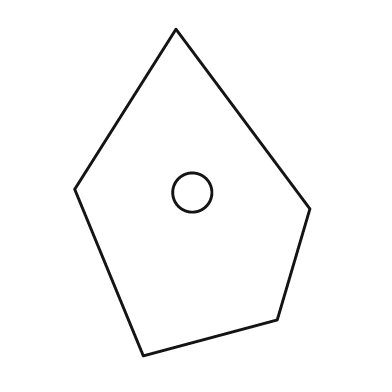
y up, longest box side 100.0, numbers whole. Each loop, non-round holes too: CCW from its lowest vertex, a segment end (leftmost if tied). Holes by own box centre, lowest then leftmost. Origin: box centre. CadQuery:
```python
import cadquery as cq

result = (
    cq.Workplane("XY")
    .moveTo(-15.0, -50.0)
    .lineTo(26.0, -39.0)
    .lineTo(36.0, -5.0)
    .lineTo(-5.0, 50.0)
    .lineTo(-36.0, 1.0)
    .close()
    .moveTo(0.0, 0.0)
    .circle(6.0)
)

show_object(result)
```